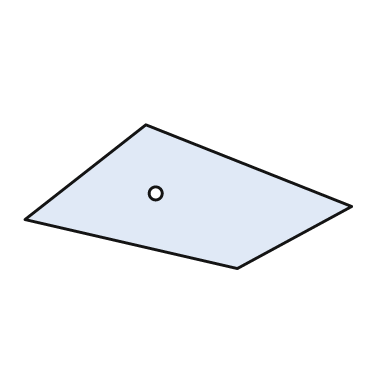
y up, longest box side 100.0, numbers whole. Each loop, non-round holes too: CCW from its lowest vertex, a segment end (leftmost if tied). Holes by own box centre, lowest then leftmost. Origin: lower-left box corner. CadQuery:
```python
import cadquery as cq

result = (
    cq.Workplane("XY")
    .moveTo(65.0, 0.0)
    .lineTo(100.0, 19.0)
    .lineTo(37.0, 44.0)
    .lineTo(0.0, 15.0)
    .close()
    .moveTo(40.0, 23.0)
    .circle(2.0)
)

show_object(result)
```